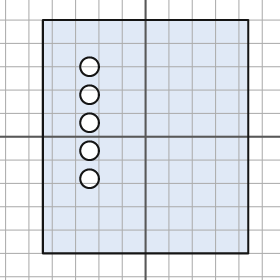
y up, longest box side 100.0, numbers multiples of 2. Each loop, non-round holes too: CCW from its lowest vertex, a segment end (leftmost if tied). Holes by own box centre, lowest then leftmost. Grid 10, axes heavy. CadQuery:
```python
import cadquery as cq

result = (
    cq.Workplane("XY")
    .moveTo(-44.0, -50.0)
    .lineTo(44.0, -50.0)
    .lineTo(44.0, 50.0)
    .lineTo(-44.0, 50.0)
    .close()
    .moveTo(-24.0, -18.0)
    .circle(4.0)
    .moveTo(-24.0, -6.0)
    .circle(4.0)
    .moveTo(-24.0, 6.0)
    .circle(4.0)
    .moveTo(-24.0, 18.0)
    .circle(4.0)
    .moveTo(-24.0, 30.0)
    .circle(4.0)
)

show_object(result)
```